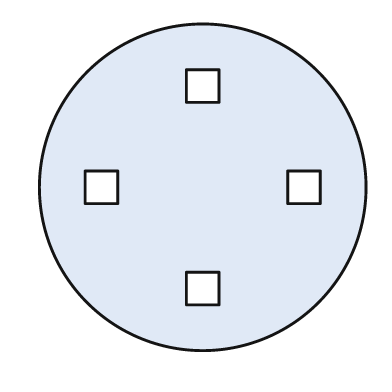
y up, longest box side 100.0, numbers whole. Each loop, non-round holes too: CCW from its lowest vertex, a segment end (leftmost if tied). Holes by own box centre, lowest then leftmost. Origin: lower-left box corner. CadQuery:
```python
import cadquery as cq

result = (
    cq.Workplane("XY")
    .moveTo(50.0, 50.0)
    .circle(50.0)
    .moveTo(45.0, 14.0)
    .lineTo(55.0, 14.0)
    .lineTo(55.0, 24.0)
    .lineTo(45.0, 24.0)
    .close()
    .moveTo(14.0, 45.0)
    .lineTo(24.0, 45.0)
    .lineTo(24.0, 55.0)
    .lineTo(14.0, 55.0)
    .close()
    .moveTo(76.0, 45.0)
    .lineTo(86.0, 45.0)
    .lineTo(86.0, 55.0)
    .lineTo(76.0, 55.0)
    .close()
    .moveTo(45.0, 76.0)
    .lineTo(55.0, 76.0)
    .lineTo(55.0, 86.0)
    .lineTo(45.0, 86.0)
    .close()
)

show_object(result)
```